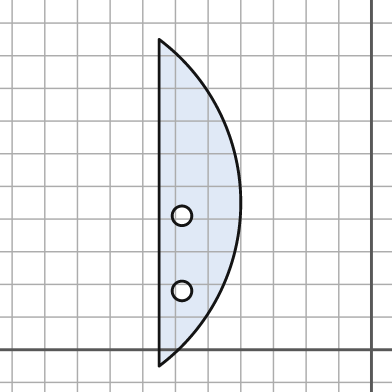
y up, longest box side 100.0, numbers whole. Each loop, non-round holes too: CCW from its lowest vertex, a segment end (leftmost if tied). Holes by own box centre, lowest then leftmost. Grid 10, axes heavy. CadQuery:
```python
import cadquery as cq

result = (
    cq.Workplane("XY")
    .moveTo(-65.0, -5.0)
    .threePointArc((-40.0, 45.0), (-65.0, 95.0))
    .close()
    .moveTo(-58.0, 18.0)
    .circle(3.0)
    .moveTo(-58.0, 41.0)
    .circle(3.0)
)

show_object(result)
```